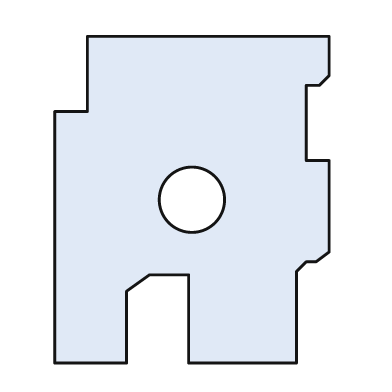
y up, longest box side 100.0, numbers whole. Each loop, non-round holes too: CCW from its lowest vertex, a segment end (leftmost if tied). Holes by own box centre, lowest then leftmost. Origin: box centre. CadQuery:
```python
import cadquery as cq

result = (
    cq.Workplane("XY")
    .moveTo(-42.0, -50.0)
    .lineTo(-20.0, -50.0)
    .lineTo(-20.0, -28.0)
    .lineTo(-13.0, -23.0)
    .lineTo(-1.0, -23.0)
    .lineTo(-1.0, -50.0)
    .lineTo(32.0, -50.0)
    .lineTo(32.0, -22.0)
    .lineTo(35.0, -19.0)
    .lineTo(38.0, -19.0)
    .lineTo(42.0, -16.0)
    .lineTo(42.0, 12.0)
    .lineTo(35.0, 12.0)
    .lineTo(35.0, 35.0)
    .lineTo(39.0, 35.0)
    .lineTo(42.0, 38.0)
    .lineTo(42.0, 50.0)
    .lineTo(-32.0, 50.0)
    .lineTo(-32.0, 27.0)
    .lineTo(-42.0, 27.0)
    .close()
    .moveTo(0.0, 0.0)
    .circle(10.0)
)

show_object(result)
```